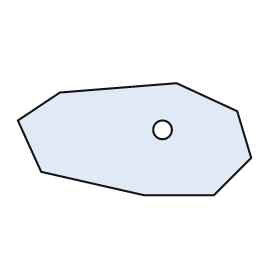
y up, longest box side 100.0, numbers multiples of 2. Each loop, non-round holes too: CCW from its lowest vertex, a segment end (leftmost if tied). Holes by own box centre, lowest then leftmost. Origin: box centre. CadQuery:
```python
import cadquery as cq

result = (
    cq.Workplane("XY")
    .moveTo(4.0, -24.0)
    .lineTo(34.0, -24.0)
    .lineTo(50.0, -8.0)
    .lineTo(44.0, 12.0)
    .lineTo(18.0, 24.0)
    .lineTo(-32.0, 20.0)
    .lineTo(-50.0, 8.0)
    .lineTo(-40.0, -14.0)
    .close()
    .moveTo(12.0, 4.0)
    .circle(4.0)
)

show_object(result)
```